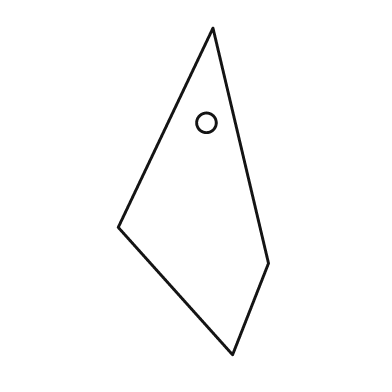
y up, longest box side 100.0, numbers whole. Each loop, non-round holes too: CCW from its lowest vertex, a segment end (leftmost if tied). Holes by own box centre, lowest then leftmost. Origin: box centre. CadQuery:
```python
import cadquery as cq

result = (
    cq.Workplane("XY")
    .moveTo(12.0, -50.0)
    .lineTo(23.0, -22.0)
    .lineTo(6.0, 50.0)
    .lineTo(-23.0, -11.0)
    .close()
    .moveTo(4.0, 21.0)
    .circle(3.0)
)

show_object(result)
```